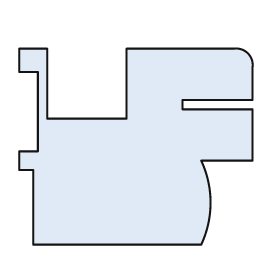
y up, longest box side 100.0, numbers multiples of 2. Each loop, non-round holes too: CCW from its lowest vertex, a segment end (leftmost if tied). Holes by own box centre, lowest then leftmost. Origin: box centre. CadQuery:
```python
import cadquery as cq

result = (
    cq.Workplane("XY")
    .moveTo(-44.0, -42.0)
    .lineTo(28.0, -42.0)
    .threePointArc((32.0, -24.0), (28.0, -6.0))
    .lineTo(50.0, -6.0)
    .lineTo(50.0, 16.0)
    .lineTo(20.0, 16.0)
    .lineTo(20.0, 20.0)
    .lineTo(50.0, 20.0)
    .lineTo(50.0, 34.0)
    .threePointArc((48.0, 40.0), (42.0, 42.0))
    .lineTo(-4.0, 42.0)
    .lineTo(-4.0, 12.0)
    .lineTo(-38.0, 12.0)
    .lineTo(-38.0, 42.0)
    .lineTo(-50.0, 42.0)
    .lineTo(-50.0, 32.0)
    .lineTo(-42.0, 32.0)
    .lineTo(-42.0, -2.0)
    .lineTo(-50.0, -2.0)
    .lineTo(-50.0, -10.0)
    .lineTo(-44.0, -10.0)
    .close()
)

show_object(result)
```